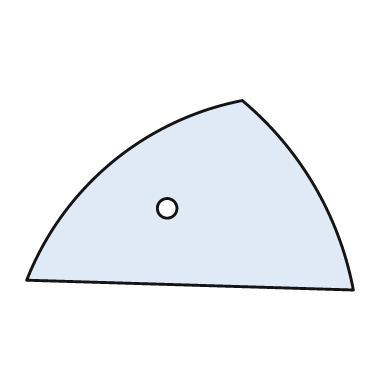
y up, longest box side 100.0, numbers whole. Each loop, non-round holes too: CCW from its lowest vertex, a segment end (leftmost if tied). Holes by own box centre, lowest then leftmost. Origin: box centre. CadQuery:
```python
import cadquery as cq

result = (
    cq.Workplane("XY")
    .moveTo(50.0, -29.0)
    .threePointArc((38.0, 3.0), (16.0, 29.0))
    .threePointArc((-24.0, 10.0), (-50.0, -26.0))
    .close()
    .moveTo(-7.0, -4.0)
    .circle(3.0)
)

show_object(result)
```